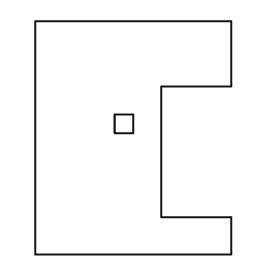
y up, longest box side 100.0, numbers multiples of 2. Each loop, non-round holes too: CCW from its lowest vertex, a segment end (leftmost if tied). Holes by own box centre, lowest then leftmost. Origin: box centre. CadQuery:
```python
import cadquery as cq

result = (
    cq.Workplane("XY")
    .moveTo(-42.0, -50.0)
    .lineTo(42.0, -50.0)
    .lineTo(42.0, -34.0)
    .lineTo(12.0, -34.0)
    .lineTo(12.0, 22.0)
    .lineTo(42.0, 22.0)
    .lineTo(42.0, 50.0)
    .lineTo(-42.0, 50.0)
    .close()
    .moveTo(-8.0, 2.0)
    .lineTo(0.0, 2.0)
    .lineTo(0.0, 10.0)
    .lineTo(-8.0, 10.0)
    .close()
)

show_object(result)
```